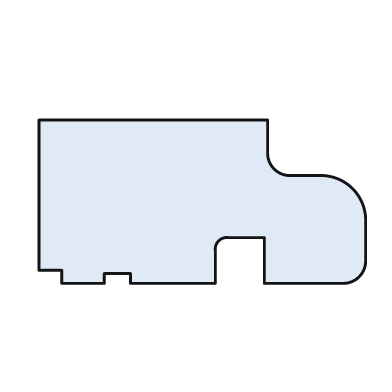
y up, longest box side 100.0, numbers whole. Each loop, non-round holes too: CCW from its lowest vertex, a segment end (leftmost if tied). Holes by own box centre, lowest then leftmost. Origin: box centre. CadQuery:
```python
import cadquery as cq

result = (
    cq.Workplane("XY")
    .moveTo(-43.0, -25.0)
    .lineTo(-30.0, -25.0)
    .lineTo(-30.0, -22.0)
    .lineTo(-22.0, -22.0)
    .lineTo(-22.0, -25.0)
    .lineTo(4.0, -25.0)
    .lineTo(4.0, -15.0)
    .threePointArc((5.0, -12.0), (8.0, -11.0))
    .lineTo(19.0, -11.0)
    .lineTo(19.0, -25.0)
    .lineTo(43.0, -25.0)
    .threePointArc((48.0, -23.0), (50.0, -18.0))
    .lineTo(50.0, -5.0)
    .threePointArc((46.0, 4.0), (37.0, 8.0))
    .lineTo(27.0, 8.0)
    .threePointArc((22.0, 10.0), (20.0, 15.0))
    .lineTo(20.0, 25.0)
    .lineTo(-50.0, 25.0)
    .lineTo(-50.0, -21.0)
    .lineTo(-43.0, -21.0)
    .close()
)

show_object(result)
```